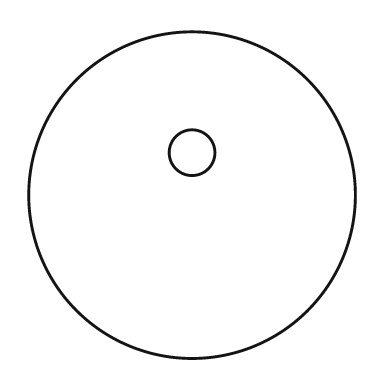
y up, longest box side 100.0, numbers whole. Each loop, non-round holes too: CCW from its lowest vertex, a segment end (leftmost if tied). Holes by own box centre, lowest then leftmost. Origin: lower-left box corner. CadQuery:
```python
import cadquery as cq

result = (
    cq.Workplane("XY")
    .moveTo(50.0, 50.0)
    .circle(50.0)
    .moveTo(50.0, 63.0)
    .circle(7.0)
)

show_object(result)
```